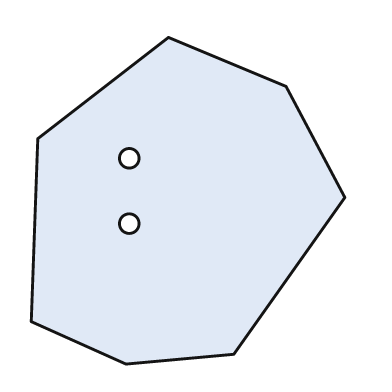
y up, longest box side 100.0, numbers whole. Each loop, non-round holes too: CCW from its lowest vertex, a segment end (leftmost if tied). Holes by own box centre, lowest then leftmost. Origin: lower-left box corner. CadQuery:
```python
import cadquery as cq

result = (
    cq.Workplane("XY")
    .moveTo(29.0, 0.0)
    .lineTo(62.0, 3.0)
    .lineTo(96.0, 51.0)
    .lineTo(78.0, 85.0)
    .lineTo(42.0, 100.0)
    .lineTo(2.0, 69.0)
    .lineTo(0.0, 13.0)
    .close()
    .moveTo(30.0, 43.0)
    .circle(3.0)
    .moveTo(30.0, 63.0)
    .circle(3.0)
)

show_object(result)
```